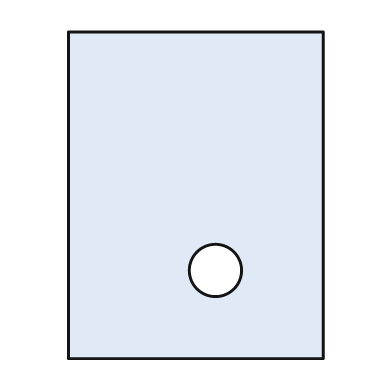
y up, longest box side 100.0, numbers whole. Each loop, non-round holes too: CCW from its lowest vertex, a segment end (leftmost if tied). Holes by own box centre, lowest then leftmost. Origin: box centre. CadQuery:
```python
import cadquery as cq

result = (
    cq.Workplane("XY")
    .moveTo(-39.0, -50.0)
    .lineTo(39.0, -50.0)
    .lineTo(39.0, 50.0)
    .lineTo(-39.0, 50.0)
    .close()
    .moveTo(6.0, -23.0)
    .circle(8.0)
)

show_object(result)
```